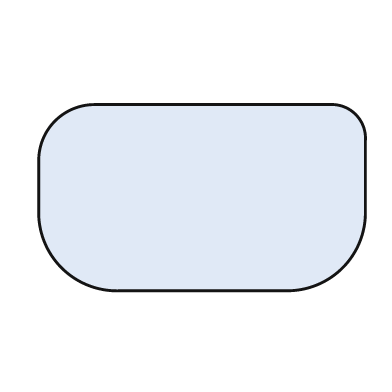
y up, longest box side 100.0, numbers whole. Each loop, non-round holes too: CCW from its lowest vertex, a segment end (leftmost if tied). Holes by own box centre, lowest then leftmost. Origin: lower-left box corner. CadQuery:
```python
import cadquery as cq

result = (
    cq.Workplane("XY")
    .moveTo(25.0, 0.0)
    .lineTo(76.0, 0.0)
    .threePointArc((93.0, 7.0), (100.0, 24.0))
    .lineTo(100.0, 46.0)
    .threePointArc((97.0, 54.0), (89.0, 57.0))
    .lineTo(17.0, 57.0)
    .threePointArc((5.0, 52.0), (0.0, 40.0))
    .lineTo(0.0, 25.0)
    .threePointArc((7.0, 7.0), (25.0, 0.0))
    .close()
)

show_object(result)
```